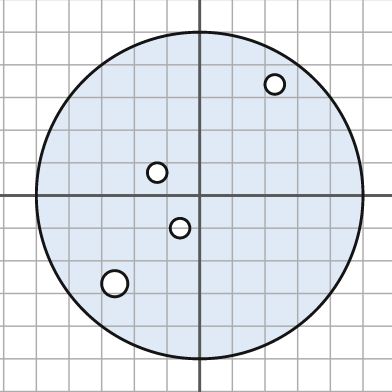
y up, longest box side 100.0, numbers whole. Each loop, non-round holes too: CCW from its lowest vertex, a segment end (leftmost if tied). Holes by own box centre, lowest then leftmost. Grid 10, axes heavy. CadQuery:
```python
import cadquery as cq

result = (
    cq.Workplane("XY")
    .moveTo(0.0, 0.0)
    .circle(50.0)
    .moveTo(-26.0, -27.0)
    .circle(4.0)
    .moveTo(-6.0, -10.0)
    .circle(3.0)
    .moveTo(-13.0, 7.0)
    .circle(3.0)
    .moveTo(23.0, 34.0)
    .circle(3.0)
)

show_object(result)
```